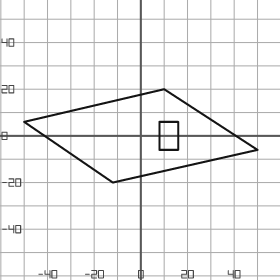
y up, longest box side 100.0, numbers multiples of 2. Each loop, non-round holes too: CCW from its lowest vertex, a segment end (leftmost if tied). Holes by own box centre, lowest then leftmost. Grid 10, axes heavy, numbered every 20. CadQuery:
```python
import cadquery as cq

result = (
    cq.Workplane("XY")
    .moveTo(-12.0, -20.0)
    .lineTo(50.0, -6.0)
    .lineTo(10.0, 20.0)
    .lineTo(-50.0, 6.0)
    .close()
    .moveTo(8.0, -6.0)
    .lineTo(16.0, -6.0)
    .lineTo(16.0, 6.0)
    .lineTo(8.0, 6.0)
    .close()
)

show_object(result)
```